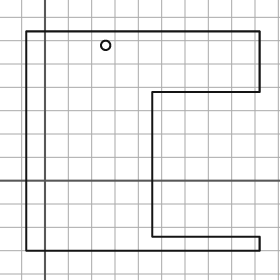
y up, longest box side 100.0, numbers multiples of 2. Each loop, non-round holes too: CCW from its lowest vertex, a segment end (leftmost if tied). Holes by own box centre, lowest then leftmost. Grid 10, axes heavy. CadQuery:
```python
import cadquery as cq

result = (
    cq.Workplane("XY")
    .moveTo(-8.0, -30.0)
    .lineTo(92.0, -30.0)
    .lineTo(92.0, -24.0)
    .lineTo(46.0, -24.0)
    .lineTo(46.0, 38.0)
    .lineTo(92.0, 38.0)
    .lineTo(92.0, 64.0)
    .lineTo(-8.0, 64.0)
    .close()
    .moveTo(26.0, 58.0)
    .circle(2.0)
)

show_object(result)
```